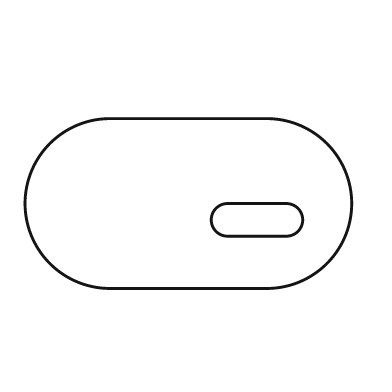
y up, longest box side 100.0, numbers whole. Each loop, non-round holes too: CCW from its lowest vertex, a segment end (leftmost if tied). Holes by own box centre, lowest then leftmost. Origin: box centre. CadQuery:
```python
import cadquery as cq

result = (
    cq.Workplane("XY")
    .moveTo(-24.0, -26.0)
    .lineTo(24.0, -26.0)
    .threePointArc((50.0, 0.0), (24.0, 26.0))
    .lineTo(-24.0, 26.0)
    .threePointArc((-50.0, 0.0), (-24.0, -26.0))
    .close()
    .moveTo(12.0, -10.0)
    .lineTo(30.0, -10.0)
    .threePointArc((35.0, -5.0), (30.0, 0.0))
    .lineTo(12.0, 0.0)
    .threePointArc((7.0, -5.0), (12.0, -10.0))
    .close()
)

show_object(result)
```